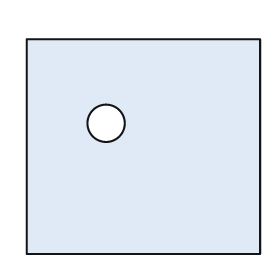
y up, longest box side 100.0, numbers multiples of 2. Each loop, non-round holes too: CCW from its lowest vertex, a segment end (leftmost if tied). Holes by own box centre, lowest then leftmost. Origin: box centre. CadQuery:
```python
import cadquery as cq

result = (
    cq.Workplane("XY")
    .moveTo(-50.0, -46.0)
    .lineTo(50.0, -46.0)
    .lineTo(50.0, 46.0)
    .lineTo(-50.0, 46.0)
    .close()
    .moveTo(-16.0, 10.0)
    .circle(8.0)
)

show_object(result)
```